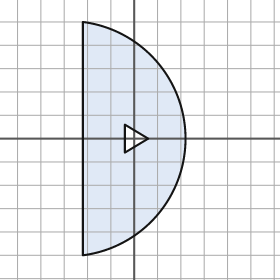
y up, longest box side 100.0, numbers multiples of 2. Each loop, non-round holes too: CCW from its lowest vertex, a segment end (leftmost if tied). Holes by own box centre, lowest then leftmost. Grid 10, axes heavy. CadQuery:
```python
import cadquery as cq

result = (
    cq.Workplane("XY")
    .moveTo(-22.0, -50.0)
    .threePointArc((22.0, 0.0), (-22.0, 50.0))
    .close()
    .moveTo(-4.0, -6.0)
    .lineTo(6.0, 0.0)
    .lineTo(-4.0, 6.0)
    .close()
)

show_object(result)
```